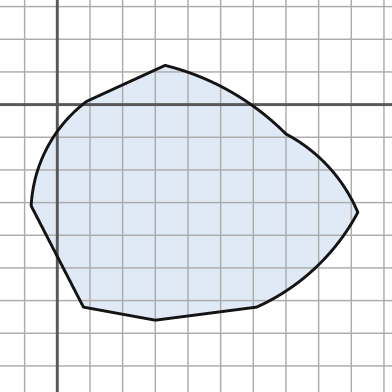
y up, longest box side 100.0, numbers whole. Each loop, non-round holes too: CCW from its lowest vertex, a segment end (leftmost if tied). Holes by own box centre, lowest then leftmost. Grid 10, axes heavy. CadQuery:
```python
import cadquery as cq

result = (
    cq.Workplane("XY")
    .moveTo(30.0, -66.0)
    .lineTo(61.0, -62.0)
    .threePointArc((79.0, -50.0), (92.0, -33.0))
    .threePointArc((83.0, -19.0), (70.0, -9.0))
    .threePointArc((53.0, 4.0), (33.0, 12.0))
    .lineTo(9.0, 1.0)
    .threePointArc((-3.0, -13.0), (-8.0, -31.0))
    .lineTo(8.0, -62.0)
    .close()
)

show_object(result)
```